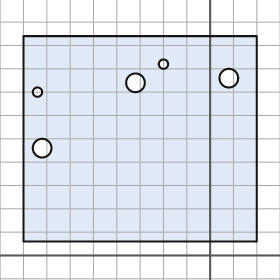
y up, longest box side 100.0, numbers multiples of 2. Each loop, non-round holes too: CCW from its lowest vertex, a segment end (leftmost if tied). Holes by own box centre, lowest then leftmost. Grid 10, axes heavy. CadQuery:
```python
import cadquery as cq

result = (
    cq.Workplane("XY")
    .moveTo(-80.0, 6.0)
    .lineTo(20.0, 6.0)
    .lineTo(20.0, 94.0)
    .lineTo(-80.0, 94.0)
    .close()
    .moveTo(-72.0, 46.0)
    .circle(4.0)
    .moveTo(-74.0, 70.0)
    .circle(2.0)
    .moveTo(-32.0, 74.0)
    .circle(4.0)
    .moveTo(8.0, 76.0)
    .circle(4.0)
    .moveTo(-20.0, 82.0)
    .circle(2.0)
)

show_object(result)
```